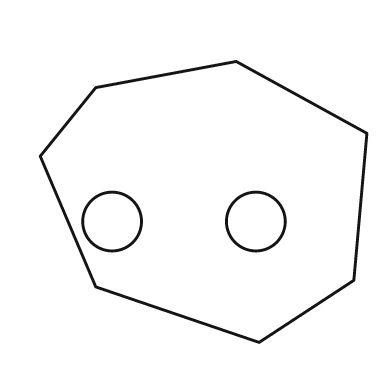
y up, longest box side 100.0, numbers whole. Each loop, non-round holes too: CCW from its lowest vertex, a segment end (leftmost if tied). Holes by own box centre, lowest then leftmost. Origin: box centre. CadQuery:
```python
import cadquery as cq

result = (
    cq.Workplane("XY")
    .moveTo(17.0, -43.0)
    .lineTo(46.0, -24.0)
    .lineTo(50.0, 21.0)
    .lineTo(10.0, 43.0)
    .lineTo(-33.0, 35.0)
    .lineTo(-50.0, 14.0)
    .lineTo(-33.0, -26.0)
    .close()
    .moveTo(-28.0, -6.0)
    .circle(9.0)
    .moveTo(16.0, -6.0)
    .circle(9.0)
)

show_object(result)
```